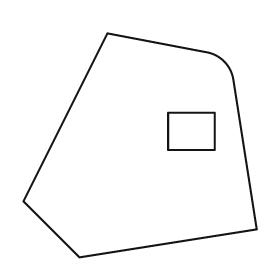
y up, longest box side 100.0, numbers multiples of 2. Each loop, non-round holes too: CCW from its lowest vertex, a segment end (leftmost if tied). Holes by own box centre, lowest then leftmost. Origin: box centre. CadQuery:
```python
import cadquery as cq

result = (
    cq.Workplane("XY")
    .moveTo(-26.0, -48.0)
    .lineTo(50.0, -36.0)
    .lineTo(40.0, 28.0)
    .threePointArc((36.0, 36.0), (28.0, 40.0))
    .lineTo(-14.0, 48.0)
    .lineTo(-50.0, -24.0)
    .close()
    .moveTo(12.0, -2.0)
    .lineTo(32.0, -2.0)
    .lineTo(32.0, 14.0)
    .lineTo(12.0, 14.0)
    .close()
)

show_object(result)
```